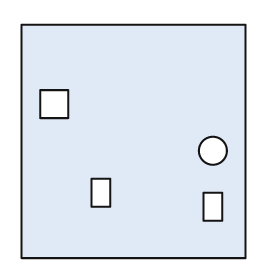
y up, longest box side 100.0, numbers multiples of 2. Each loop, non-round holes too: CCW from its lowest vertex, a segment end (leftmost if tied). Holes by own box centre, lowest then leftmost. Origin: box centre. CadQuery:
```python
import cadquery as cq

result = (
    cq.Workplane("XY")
    .moveTo(-48.0, -50.0)
    .lineTo(48.0, -50.0)
    .lineTo(48.0, 50.0)
    .lineTo(-48.0, 50.0)
    .close()
    .moveTo(30.0, -34.0)
    .lineTo(38.0, -34.0)
    .lineTo(38.0, -22.0)
    .lineTo(30.0, -22.0)
    .close()
    .moveTo(-18.0, -28.0)
    .lineTo(-10.0, -28.0)
    .lineTo(-10.0, -16.0)
    .lineTo(-18.0, -16.0)
    .close()
    .moveTo(34.0, -4.0)
    .circle(6.0)
    .moveTo(-40.0, 10.0)
    .lineTo(-28.0, 10.0)
    .lineTo(-28.0, 22.0)
    .lineTo(-40.0, 22.0)
    .close()
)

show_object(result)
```